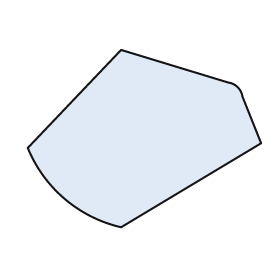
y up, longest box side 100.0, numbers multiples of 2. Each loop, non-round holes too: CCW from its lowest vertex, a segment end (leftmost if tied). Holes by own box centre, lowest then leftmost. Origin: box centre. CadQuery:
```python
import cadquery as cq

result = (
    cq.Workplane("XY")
    .moveTo(-10.0, -38.0)
    .lineTo(50.0, -2.0)
    .lineTo(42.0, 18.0)
    .threePointArc((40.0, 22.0), (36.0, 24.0))
    .lineTo(-10.0, 38.0)
    .lineTo(-50.0, -4.0)
    .threePointArc((-34.0, -26.0), (-10.0, -38.0))
    .close()
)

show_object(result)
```